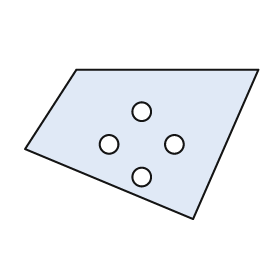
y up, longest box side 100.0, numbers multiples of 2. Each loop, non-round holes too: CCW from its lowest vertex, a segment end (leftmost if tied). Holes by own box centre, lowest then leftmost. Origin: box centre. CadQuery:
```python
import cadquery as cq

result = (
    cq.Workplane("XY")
    .moveTo(22.0, -32.0)
    .lineTo(50.0, 32.0)
    .lineTo(-28.0, 32.0)
    .lineTo(-50.0, -2.0)
    .close()
    .moveTo(0.0, -14.0)
    .circle(4.0)
    .moveTo(-14.0, 0.0)
    .circle(4.0)
    .moveTo(14.0, 0.0)
    .circle(4.0)
    .moveTo(0.0, 14.0)
    .circle(4.0)
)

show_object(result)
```